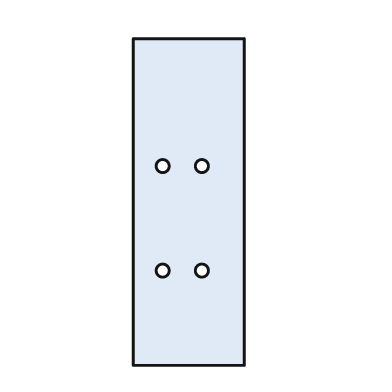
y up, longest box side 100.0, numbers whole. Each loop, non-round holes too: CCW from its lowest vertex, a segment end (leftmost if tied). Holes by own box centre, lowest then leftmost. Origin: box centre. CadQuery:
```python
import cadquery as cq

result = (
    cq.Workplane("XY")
    .moveTo(-17.0, -50.0)
    .lineTo(17.0, -50.0)
    .lineTo(17.0, 50.0)
    .lineTo(-17.0, 50.0)
    .close()
    .moveTo(-8.0, -21.0)
    .circle(2.0)
    .moveTo(4.0, -21.0)
    .circle(2.0)
    .moveTo(-8.0, 11.0)
    .circle(2.0)
    .moveTo(4.0, 11.0)
    .circle(2.0)
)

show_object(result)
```